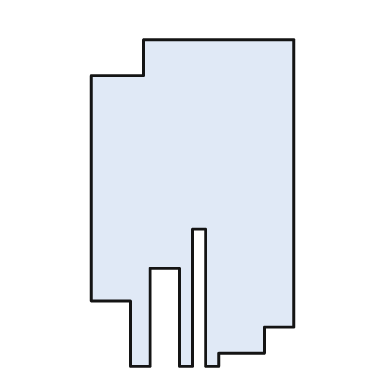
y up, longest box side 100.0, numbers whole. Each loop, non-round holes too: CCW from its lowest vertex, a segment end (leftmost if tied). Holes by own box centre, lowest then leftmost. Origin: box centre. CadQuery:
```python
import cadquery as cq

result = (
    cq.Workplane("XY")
    .moveTo(-19.0, -50.0)
    .lineTo(-13.0, -50.0)
    .lineTo(-13.0, -20.0)
    .lineTo(-4.0, -20.0)
    .lineTo(-4.0, -50.0)
    .lineTo(0.0, -50.0)
    .lineTo(0.0, -8.0)
    .lineTo(4.0, -8.0)
    .lineTo(4.0, -50.0)
    .lineTo(8.0, -50.0)
    .lineTo(8.0, -46.0)
    .lineTo(22.0, -46.0)
    .lineTo(22.0, -38.0)
    .lineTo(31.0, -38.0)
    .lineTo(31.0, 50.0)
    .lineTo(-15.0, 50.0)
    .lineTo(-15.0, 39.0)
    .lineTo(-31.0, 39.0)
    .lineTo(-31.0, -30.0)
    .lineTo(-19.0, -30.0)
    .close()
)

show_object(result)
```